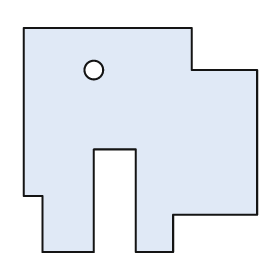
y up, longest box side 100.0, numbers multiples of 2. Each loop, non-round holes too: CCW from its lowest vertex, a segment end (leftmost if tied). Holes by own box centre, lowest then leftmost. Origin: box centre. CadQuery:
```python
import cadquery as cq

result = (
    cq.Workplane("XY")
    .moveTo(-42.0, -48.0)
    .lineTo(-20.0, -48.0)
    .lineTo(-20.0, -4.0)
    .lineTo(-2.0, -4.0)
    .lineTo(-2.0, -48.0)
    .lineTo(14.0, -48.0)
    .lineTo(14.0, -32.0)
    .lineTo(50.0, -32.0)
    .lineTo(50.0, 30.0)
    .lineTo(22.0, 30.0)
    .lineTo(22.0, 48.0)
    .lineTo(-50.0, 48.0)
    .lineTo(-50.0, -24.0)
    .lineTo(-42.0, -24.0)
    .close()
    .moveTo(-20.0, 30.0)
    .circle(4.0)
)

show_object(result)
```